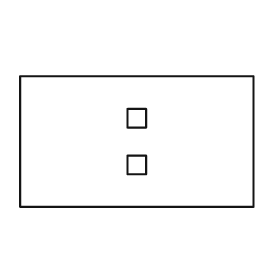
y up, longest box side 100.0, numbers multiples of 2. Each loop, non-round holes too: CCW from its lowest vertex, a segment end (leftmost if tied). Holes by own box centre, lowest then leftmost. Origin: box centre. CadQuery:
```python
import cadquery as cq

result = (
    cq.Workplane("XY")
    .moveTo(-50.0, -28.0)
    .lineTo(50.0, -28.0)
    .lineTo(50.0, 28.0)
    .lineTo(-50.0, 28.0)
    .close()
    .moveTo(-4.0, -14.0)
    .lineTo(4.0, -14.0)
    .lineTo(4.0, -6.0)
    .lineTo(-4.0, -6.0)
    .close()
    .moveTo(-4.0, 6.0)
    .lineTo(4.0, 6.0)
    .lineTo(4.0, 14.0)
    .lineTo(-4.0, 14.0)
    .close()
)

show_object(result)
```